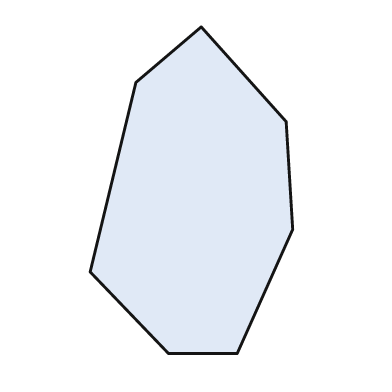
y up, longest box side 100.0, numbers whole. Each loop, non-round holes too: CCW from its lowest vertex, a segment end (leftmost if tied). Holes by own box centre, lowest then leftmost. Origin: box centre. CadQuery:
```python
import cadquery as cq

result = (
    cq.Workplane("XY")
    .moveTo(-7.0, -50.0)
    .lineTo(14.0, -50.0)
    .lineTo(31.0, -12.0)
    .lineTo(29.0, 21.0)
    .lineTo(3.0, 50.0)
    .lineTo(-17.0, 33.0)
    .lineTo(-31.0, -25.0)
    .close()
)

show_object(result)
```